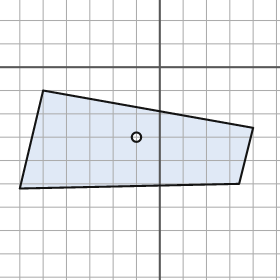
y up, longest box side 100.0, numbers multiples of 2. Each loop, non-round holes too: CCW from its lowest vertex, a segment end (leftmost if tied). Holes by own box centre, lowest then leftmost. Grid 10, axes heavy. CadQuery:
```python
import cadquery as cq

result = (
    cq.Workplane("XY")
    .moveTo(-60.0, -52.0)
    .lineTo(34.0, -50.0)
    .lineTo(40.0, -26.0)
    .lineTo(-50.0, -10.0)
    .close()
    .moveTo(-10.0, -30.0)
    .circle(2.0)
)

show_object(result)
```